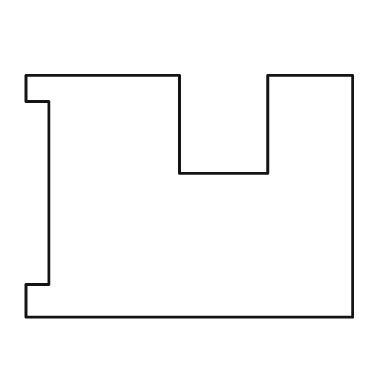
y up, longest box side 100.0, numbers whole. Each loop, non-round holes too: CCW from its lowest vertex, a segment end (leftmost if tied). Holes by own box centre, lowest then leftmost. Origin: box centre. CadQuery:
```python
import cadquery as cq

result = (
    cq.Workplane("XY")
    .moveTo(-50.0, -37.0)
    .lineTo(50.0, -37.0)
    .lineTo(50.0, 37.0)
    .lineTo(24.0, 37.0)
    .lineTo(24.0, 7.0)
    .lineTo(-3.0, 7.0)
    .lineTo(-3.0, 37.0)
    .lineTo(-50.0, 37.0)
    .lineTo(-50.0, 29.0)
    .lineTo(-43.0, 29.0)
    .lineTo(-43.0, -27.0)
    .lineTo(-50.0, -27.0)
    .close()
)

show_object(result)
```